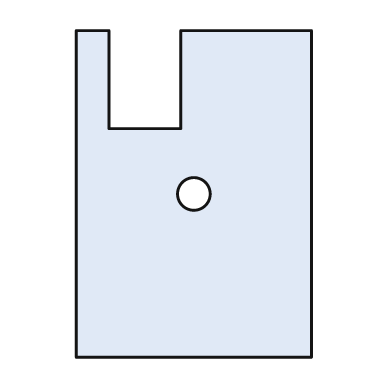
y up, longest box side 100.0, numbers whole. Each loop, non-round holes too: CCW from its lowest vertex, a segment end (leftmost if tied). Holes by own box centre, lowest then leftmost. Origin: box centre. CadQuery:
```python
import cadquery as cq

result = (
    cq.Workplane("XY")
    .moveTo(-36.0, -50.0)
    .lineTo(36.0, -50.0)
    .lineTo(36.0, 50.0)
    .lineTo(-4.0, 50.0)
    .lineTo(-4.0, 20.0)
    .lineTo(-26.0, 20.0)
    .lineTo(-26.0, 50.0)
    .lineTo(-36.0, 50.0)
    .close()
    .moveTo(0.0, 0.0)
    .circle(5.0)
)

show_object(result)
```